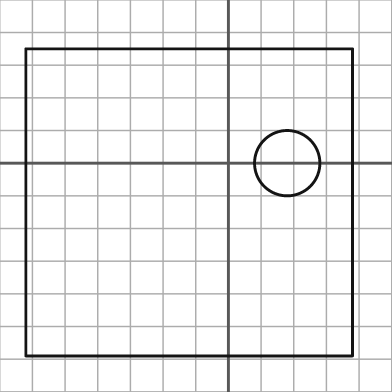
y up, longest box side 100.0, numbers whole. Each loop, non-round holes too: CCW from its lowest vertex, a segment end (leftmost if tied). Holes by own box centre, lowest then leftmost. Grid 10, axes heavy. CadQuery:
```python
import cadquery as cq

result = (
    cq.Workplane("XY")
    .moveTo(-62.0, -59.0)
    .lineTo(38.0, -59.0)
    .lineTo(38.0, 35.0)
    .lineTo(-62.0, 35.0)
    .close()
    .moveTo(18.0, 0.0)
    .circle(10.0)
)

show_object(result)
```